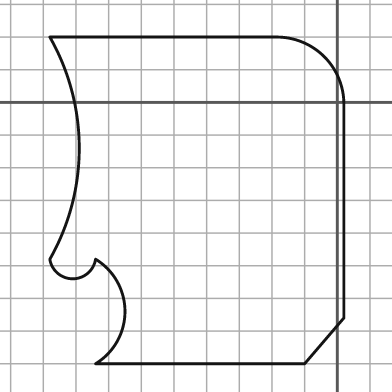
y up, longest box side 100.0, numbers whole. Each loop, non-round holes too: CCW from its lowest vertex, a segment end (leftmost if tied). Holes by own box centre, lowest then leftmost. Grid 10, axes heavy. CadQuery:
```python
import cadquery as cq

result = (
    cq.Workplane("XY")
    .moveTo(-74.0, -80.0)
    .lineTo(-10.0, -80.0)
    .lineTo(2.0, -66.0)
    .lineTo(2.0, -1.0)
    .threePointArc((-4.0, 14.0), (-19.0, 20.0))
    .lineTo(-88.0, 20.0)
    .threePointArc((-79.0, -14.0), (-88.0, -48.0))
    .threePointArc((-81.0, -54.0), (-74.0, -48.0))
    .threePointArc((-65.0, -64.0), (-74.0, -80.0))
    .close()
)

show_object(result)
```